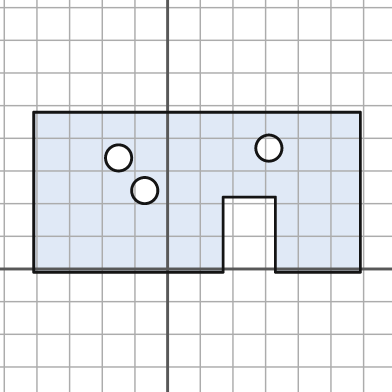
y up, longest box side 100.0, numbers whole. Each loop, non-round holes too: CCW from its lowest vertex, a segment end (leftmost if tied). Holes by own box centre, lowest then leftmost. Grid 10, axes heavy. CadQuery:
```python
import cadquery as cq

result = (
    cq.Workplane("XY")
    .moveTo(-41.0, -1.0)
    .lineTo(17.0, -1.0)
    .lineTo(17.0, 22.0)
    .lineTo(33.0, 22.0)
    .lineTo(33.0, -1.0)
    .lineTo(59.0, -1.0)
    .lineTo(59.0, 48.0)
    .lineTo(-41.0, 48.0)
    .close()
    .moveTo(-7.0, 24.0)
    .circle(4.0)
    .moveTo(-15.0, 34.0)
    .circle(4.0)
    .moveTo(31.0, 37.0)
    .circle(4.0)
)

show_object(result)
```